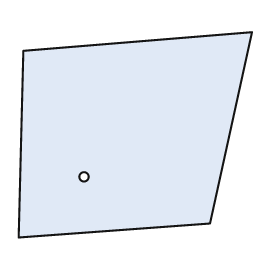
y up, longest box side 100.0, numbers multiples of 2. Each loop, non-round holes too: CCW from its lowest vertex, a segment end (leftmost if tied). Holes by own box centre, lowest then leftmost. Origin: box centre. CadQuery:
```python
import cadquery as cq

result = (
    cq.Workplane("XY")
    .moveTo(-50.0, -44.0)
    .lineTo(32.0, -38.0)
    .lineTo(50.0, 44.0)
    .lineTo(-48.0, 36.0)
    .close()
    .moveTo(-22.0, -18.0)
    .circle(2.0)
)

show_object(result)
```